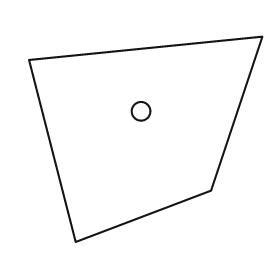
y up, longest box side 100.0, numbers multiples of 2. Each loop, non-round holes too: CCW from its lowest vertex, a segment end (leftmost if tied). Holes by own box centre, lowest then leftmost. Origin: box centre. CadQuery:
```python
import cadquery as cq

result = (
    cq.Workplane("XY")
    .moveTo(-30.0, -44.0)
    .lineTo(28.0, -22.0)
    .lineTo(50.0, 44.0)
    .lineTo(-50.0, 34.0)
    .close()
    .moveTo(-2.0, 12.0)
    .circle(4.0)
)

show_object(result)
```